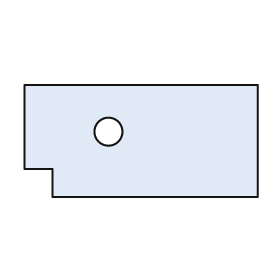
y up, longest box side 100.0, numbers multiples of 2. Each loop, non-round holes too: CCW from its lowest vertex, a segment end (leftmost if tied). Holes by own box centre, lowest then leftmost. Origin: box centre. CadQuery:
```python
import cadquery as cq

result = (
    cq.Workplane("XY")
    .moveTo(-38.0, -24.0)
    .lineTo(50.0, -24.0)
    .lineTo(50.0, 24.0)
    .lineTo(-50.0, 24.0)
    .lineTo(-50.0, -12.0)
    .lineTo(-38.0, -12.0)
    .close()
    .moveTo(-14.0, 4.0)
    .circle(6.0)
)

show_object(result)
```